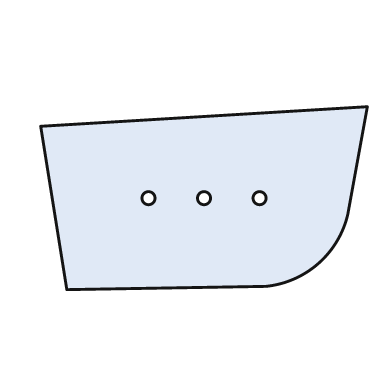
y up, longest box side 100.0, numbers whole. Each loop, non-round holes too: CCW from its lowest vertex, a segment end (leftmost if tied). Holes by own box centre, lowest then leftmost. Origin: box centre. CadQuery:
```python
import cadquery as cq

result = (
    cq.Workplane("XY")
    .moveTo(-42.0, -28.0)
    .lineTo(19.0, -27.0)
    .threePointArc((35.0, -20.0), (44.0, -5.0))
    .lineTo(50.0, 28.0)
    .lineTo(-50.0, 22.0)
    .close()
    .moveTo(-17.0, 0.0)
    .circle(2.0)
    .moveTo(0.0, 0.0)
    .circle(2.0)
    .moveTo(17.0, 0.0)
    .circle(2.0)
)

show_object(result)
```